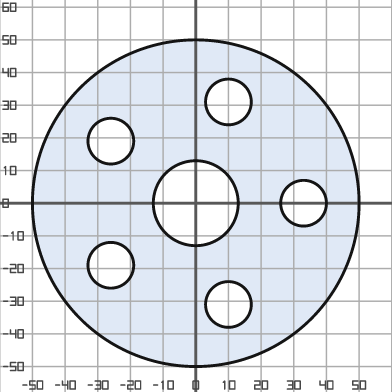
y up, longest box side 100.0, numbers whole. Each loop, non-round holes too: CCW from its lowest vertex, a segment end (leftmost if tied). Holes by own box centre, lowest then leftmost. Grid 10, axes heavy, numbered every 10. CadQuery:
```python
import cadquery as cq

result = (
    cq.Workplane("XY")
    .moveTo(0.0, 0.0)
    .circle(50.0)
    .moveTo(10.0, -31.0)
    .circle(7.0)
    .moveTo(-26.0, -19.0)
    .circle(7.0)
    .moveTo(0.0, 0.0)
    .circle(13.0)
    .moveTo(33.0, 0.0)
    .circle(7.0)
    .moveTo(-26.0, 19.0)
    .circle(7.0)
    .moveTo(10.0, 31.0)
    .circle(7.0)
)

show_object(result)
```